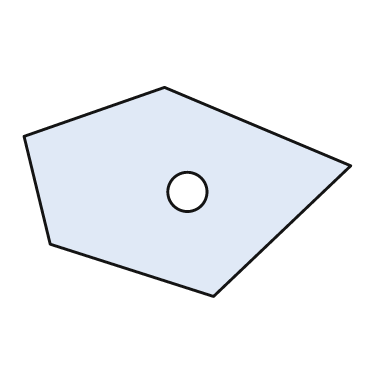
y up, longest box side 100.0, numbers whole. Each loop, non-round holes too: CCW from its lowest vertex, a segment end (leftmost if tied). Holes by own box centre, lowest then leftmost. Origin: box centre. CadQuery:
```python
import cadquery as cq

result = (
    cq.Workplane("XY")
    .moveTo(8.0, -32.0)
    .lineTo(50.0, 8.0)
    .lineTo(-7.0, 32.0)
    .lineTo(-50.0, 17.0)
    .lineTo(-42.0, -16.0)
    .close()
    .moveTo(0.0, 0.0)
    .circle(6.0)
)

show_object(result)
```